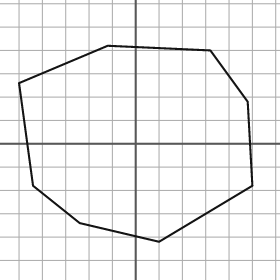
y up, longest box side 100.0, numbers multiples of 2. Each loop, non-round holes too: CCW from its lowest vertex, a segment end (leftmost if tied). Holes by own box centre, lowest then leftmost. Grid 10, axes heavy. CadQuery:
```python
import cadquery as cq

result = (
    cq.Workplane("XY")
    .moveTo(10.0, -42.0)
    .lineTo(50.0, -18.0)
    .lineTo(48.0, 18.0)
    .lineTo(32.0, 40.0)
    .lineTo(-12.0, 42.0)
    .lineTo(-50.0, 26.0)
    .lineTo(-44.0, -18.0)
    .lineTo(-24.0, -34.0)
    .close()
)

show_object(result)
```